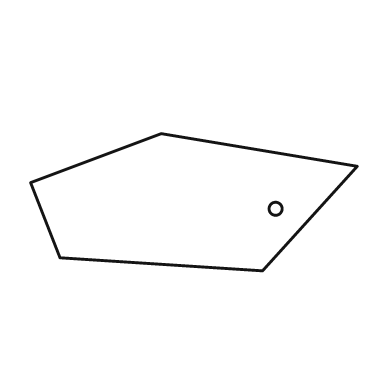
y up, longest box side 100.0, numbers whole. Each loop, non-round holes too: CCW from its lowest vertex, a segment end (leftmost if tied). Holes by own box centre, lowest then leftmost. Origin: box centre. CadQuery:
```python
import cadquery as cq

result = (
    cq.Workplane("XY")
    .moveTo(21.0, -21.0)
    .lineTo(50.0, 11.0)
    .lineTo(-10.0, 21.0)
    .lineTo(-50.0, 6.0)
    .lineTo(-41.0, -17.0)
    .close()
    .moveTo(25.0, -2.0)
    .circle(2.0)
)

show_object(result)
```